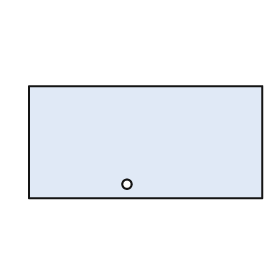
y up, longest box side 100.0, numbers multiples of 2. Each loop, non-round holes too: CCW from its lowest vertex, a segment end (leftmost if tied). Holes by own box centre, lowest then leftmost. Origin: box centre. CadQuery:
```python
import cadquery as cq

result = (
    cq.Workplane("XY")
    .moveTo(-50.0, -24.0)
    .lineTo(50.0, -24.0)
    .lineTo(50.0, 24.0)
    .lineTo(-50.0, 24.0)
    .close()
    .moveTo(-8.0, -18.0)
    .circle(2.0)
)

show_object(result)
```